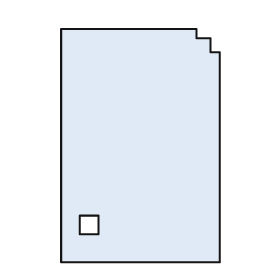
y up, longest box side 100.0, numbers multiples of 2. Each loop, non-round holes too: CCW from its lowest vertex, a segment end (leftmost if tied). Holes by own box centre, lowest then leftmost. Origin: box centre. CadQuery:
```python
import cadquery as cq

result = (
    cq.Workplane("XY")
    .moveTo(-34.0, -50.0)
    .lineTo(34.0, -50.0)
    .lineTo(34.0, 40.0)
    .lineTo(30.0, 40.0)
    .lineTo(30.0, 46.0)
    .lineTo(24.0, 46.0)
    .lineTo(24.0, 50.0)
    .lineTo(-34.0, 50.0)
    .close()
    .moveTo(-26.0, -38.0)
    .lineTo(-18.0, -38.0)
    .lineTo(-18.0, -30.0)
    .lineTo(-26.0, -30.0)
    .close()
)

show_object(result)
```